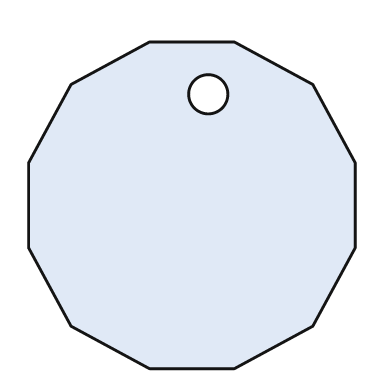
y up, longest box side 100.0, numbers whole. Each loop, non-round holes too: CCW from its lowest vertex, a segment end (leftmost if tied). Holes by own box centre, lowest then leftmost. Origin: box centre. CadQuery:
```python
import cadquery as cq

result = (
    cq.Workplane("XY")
    .moveTo(-13.0, -50.0)
    .lineTo(13.0, -50.0)
    .lineTo(37.0, -37.0)
    .lineTo(50.0, -13.0)
    .lineTo(50.0, 13.0)
    .lineTo(37.0, 37.0)
    .lineTo(13.0, 50.0)
    .lineTo(-13.0, 50.0)
    .lineTo(-37.0, 37.0)
    .lineTo(-50.0, 13.0)
    .lineTo(-50.0, -13.0)
    .lineTo(-37.0, -37.0)
    .close()
    .moveTo(5.0, 34.0)
    .circle(6.0)
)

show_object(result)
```